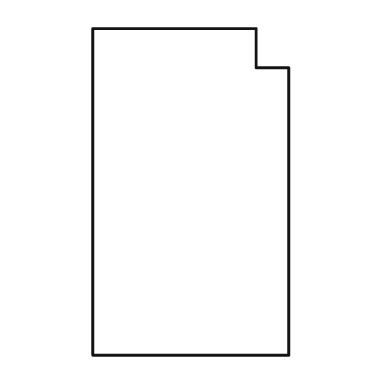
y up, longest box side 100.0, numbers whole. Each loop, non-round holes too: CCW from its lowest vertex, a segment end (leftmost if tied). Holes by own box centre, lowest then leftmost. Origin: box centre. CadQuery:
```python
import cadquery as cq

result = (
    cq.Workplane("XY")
    .moveTo(-30.0, -50.0)
    .lineTo(30.0, -50.0)
    .lineTo(30.0, 38.0)
    .lineTo(20.0, 38.0)
    .lineTo(20.0, 50.0)
    .lineTo(-30.0, 50.0)
    .close()
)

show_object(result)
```